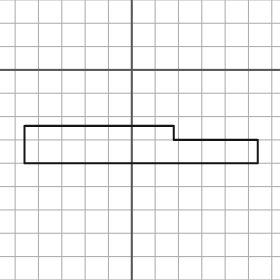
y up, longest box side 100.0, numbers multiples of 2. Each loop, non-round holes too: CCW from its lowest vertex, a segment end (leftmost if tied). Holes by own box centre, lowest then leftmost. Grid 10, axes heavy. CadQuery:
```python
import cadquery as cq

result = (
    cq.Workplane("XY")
    .moveTo(-46.0, -40.0)
    .lineTo(54.0, -40.0)
    .lineTo(54.0, -30.0)
    .lineTo(18.0, -30.0)
    .lineTo(18.0, -24.0)
    .lineTo(-46.0, -24.0)
    .close()
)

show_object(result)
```